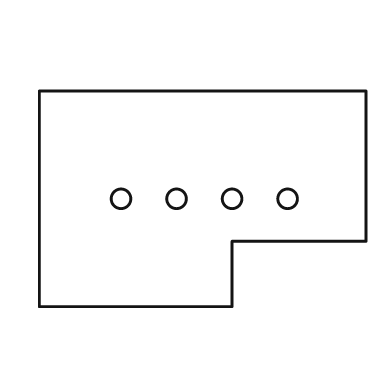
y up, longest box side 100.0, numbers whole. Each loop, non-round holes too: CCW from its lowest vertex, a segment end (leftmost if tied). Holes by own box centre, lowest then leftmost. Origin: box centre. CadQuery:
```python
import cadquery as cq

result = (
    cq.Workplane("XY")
    .moveTo(-50.0, -33.0)
    .lineTo(9.0, -33.0)
    .lineTo(9.0, -13.0)
    .lineTo(50.0, -13.0)
    .lineTo(50.0, 33.0)
    .lineTo(-50.0, 33.0)
    .close()
    .moveTo(-25.0, 0.0)
    .circle(3.0)
    .moveTo(-8.0, 0.0)
    .circle(3.0)
    .moveTo(9.0, 0.0)
    .circle(3.0)
    .moveTo(26.0, 0.0)
    .circle(3.0)
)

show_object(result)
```